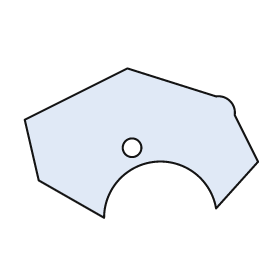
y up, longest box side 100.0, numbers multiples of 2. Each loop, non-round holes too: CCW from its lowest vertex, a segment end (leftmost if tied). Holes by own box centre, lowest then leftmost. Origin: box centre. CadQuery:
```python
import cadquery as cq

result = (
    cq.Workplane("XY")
    .moveTo(-16.0, -32.0)
    .threePointArc((6.0, -8.0), (32.0, -28.0))
    .lineTo(50.0, -8.0)
    .lineTo(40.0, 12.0)
    .threePointArc((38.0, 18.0), (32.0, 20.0))
    .lineTo(-6.0, 32.0)
    .lineTo(-50.0, 10.0)
    .lineTo(-44.0, -16.0)
    .close()
    .moveTo(-4.0, -2.0)
    .circle(4.0)
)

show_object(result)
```